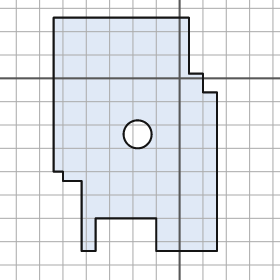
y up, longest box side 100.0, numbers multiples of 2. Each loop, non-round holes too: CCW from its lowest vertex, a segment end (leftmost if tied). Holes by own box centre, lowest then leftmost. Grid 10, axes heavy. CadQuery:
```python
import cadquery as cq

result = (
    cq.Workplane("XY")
    .moveTo(-42.0, -74.0)
    .lineTo(-36.0, -74.0)
    .lineTo(-36.0, -60.0)
    .lineTo(-10.0, -60.0)
    .lineTo(-10.0, -74.0)
    .lineTo(16.0, -74.0)
    .lineTo(16.0, -6.0)
    .lineTo(10.0, -6.0)
    .lineTo(10.0, 2.0)
    .lineTo(4.0, 2.0)
    .lineTo(4.0, 26.0)
    .lineTo(-54.0, 26.0)
    .lineTo(-54.0, -40.0)
    .lineTo(-50.0, -40.0)
    .lineTo(-50.0, -44.0)
    .lineTo(-42.0, -44.0)
    .close()
    .moveTo(-18.0, -24.0)
    .circle(6.0)
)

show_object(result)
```